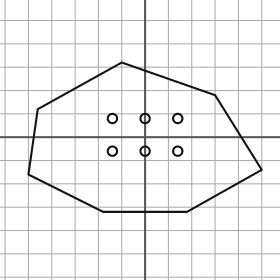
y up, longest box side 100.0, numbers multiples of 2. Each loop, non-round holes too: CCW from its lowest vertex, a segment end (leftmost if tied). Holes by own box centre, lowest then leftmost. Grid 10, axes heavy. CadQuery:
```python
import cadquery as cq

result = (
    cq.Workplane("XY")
    .moveTo(-18.0, -32.0)
    .lineTo(18.0, -32.0)
    .lineTo(50.0, -14.0)
    .lineTo(30.0, 18.0)
    .lineTo(-10.0, 32.0)
    .lineTo(-46.0, 12.0)
    .lineTo(-50.0, -16.0)
    .close()
    .moveTo(-14.0, -6.0)
    .circle(2.0)
    .moveTo(0.0, -6.0)
    .circle(2.0)
    .moveTo(14.0, -6.0)
    .circle(2.0)
    .moveTo(-14.0, 8.0)
    .circle(2.0)
    .moveTo(0.0, 8.0)
    .circle(2.0)
    .moveTo(14.0, 8.0)
    .circle(2.0)
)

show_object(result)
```